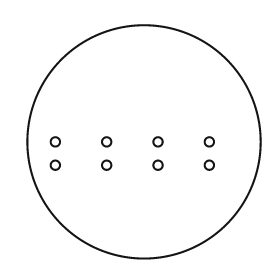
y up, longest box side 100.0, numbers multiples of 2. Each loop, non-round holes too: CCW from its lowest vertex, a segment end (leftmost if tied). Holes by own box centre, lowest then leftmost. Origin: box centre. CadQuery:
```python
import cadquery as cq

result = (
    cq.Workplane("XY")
    .moveTo(0.0, 0.0)
    .circle(50.0)
    .moveTo(-38.0, -10.0)
    .circle(2.0)
    .moveTo(-16.0, -10.0)
    .circle(2.0)
    .moveTo(6.0, -10.0)
    .circle(2.0)
    .moveTo(28.0, -10.0)
    .circle(2.0)
    .moveTo(-38.0, 0.0)
    .circle(2.0)
    .moveTo(-16.0, 0.0)
    .circle(2.0)
    .moveTo(6.0, 0.0)
    .circle(2.0)
    .moveTo(28.0, 0.0)
    .circle(2.0)
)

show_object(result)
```